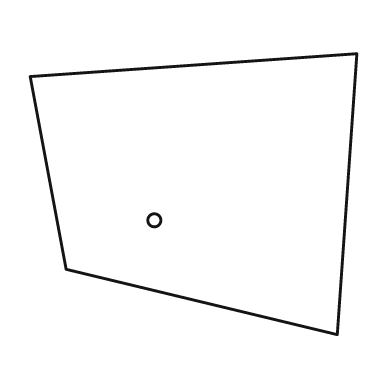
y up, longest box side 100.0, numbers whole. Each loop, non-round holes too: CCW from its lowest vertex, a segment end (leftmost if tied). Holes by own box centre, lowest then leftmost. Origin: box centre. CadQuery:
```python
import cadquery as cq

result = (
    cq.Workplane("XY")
    .moveTo(44.0, -43.0)
    .lineTo(50.0, 43.0)
    .lineTo(-50.0, 36.0)
    .lineTo(-39.0, -23.0)
    .close()
    .moveTo(-12.0, -8.0)
    .circle(2.0)
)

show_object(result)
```